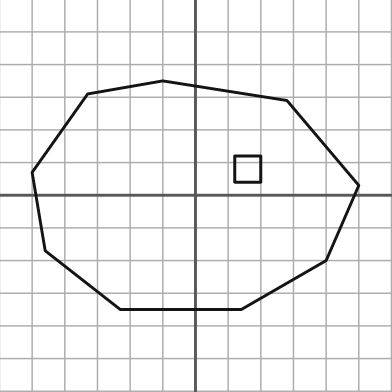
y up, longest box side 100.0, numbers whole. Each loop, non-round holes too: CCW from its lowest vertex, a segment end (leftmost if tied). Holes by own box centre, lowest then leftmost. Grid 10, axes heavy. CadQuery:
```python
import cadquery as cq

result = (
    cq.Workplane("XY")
    .moveTo(-23.0, -35.0)
    .lineTo(14.0, -35.0)
    .lineTo(40.0, -20.0)
    .lineTo(50.0, 3.0)
    .lineTo(28.0, 29.0)
    .lineTo(-10.0, 35.0)
    .lineTo(-33.0, 31.0)
    .lineTo(-50.0, 7.0)
    .lineTo(-46.0, -17.0)
    .close()
    .moveTo(12.0, 4.0)
    .lineTo(20.0, 4.0)
    .lineTo(20.0, 12.0)
    .lineTo(12.0, 12.0)
    .close()
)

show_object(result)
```